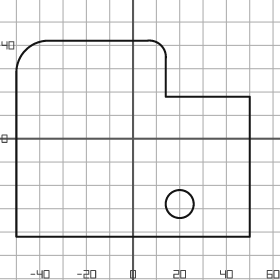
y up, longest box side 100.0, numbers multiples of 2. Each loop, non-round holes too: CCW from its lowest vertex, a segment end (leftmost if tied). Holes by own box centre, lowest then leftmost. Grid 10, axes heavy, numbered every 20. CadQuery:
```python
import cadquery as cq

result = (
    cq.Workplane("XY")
    .moveTo(-50.0, -42.0)
    .lineTo(50.0, -42.0)
    .lineTo(50.0, 18.0)
    .lineTo(14.0, 18.0)
    .lineTo(14.0, 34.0)
    .threePointArc((12.0, 40.0), (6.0, 42.0))
    .lineTo(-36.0, 42.0)
    .threePointArc((-46.0, 38.0), (-50.0, 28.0))
    .close()
    .moveTo(20.0, -28.0)
    .circle(6.0)
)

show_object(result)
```